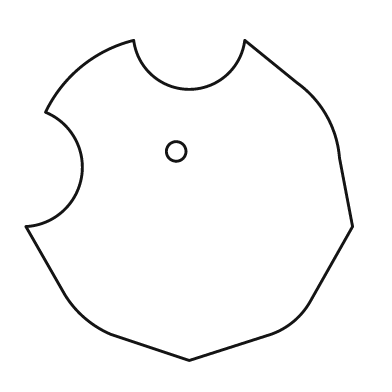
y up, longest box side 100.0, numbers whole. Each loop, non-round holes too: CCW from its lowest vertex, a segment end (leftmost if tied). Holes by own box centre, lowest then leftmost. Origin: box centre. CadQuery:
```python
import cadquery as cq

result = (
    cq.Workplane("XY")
    .moveTo(0.0, -49.0)
    .lineTo(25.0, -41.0)
    .threePointArc((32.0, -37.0), (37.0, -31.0))
    .lineTo(50.0, -8.0)
    .lineTo(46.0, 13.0)
    .threePointArc((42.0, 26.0), (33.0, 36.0))
    .lineTo(17.0, 49.0)
    .threePointArc((0.0, 34.0), (-17.0, 49.0))
    .threePointArc((-33.0, 41.0), (-44.0, 27.0))
    .threePointArc((-33.0, 7.0), (-50.0, -8.0))
    .lineTo(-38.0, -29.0)
    .threePointArc((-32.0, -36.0), (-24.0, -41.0))
    .close()
    .moveTo(-4.0, 15.0)
    .circle(3.0)
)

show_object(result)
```